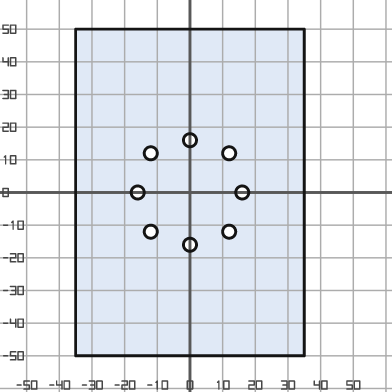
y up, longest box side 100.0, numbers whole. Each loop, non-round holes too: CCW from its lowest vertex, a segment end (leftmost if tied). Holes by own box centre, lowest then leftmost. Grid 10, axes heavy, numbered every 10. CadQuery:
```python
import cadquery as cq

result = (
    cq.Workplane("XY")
    .moveTo(-35.0, -50.0)
    .lineTo(35.0, -50.0)
    .lineTo(35.0, 50.0)
    .lineTo(-35.0, 50.0)
    .close()
    .moveTo(0.0, -16.0)
    .circle(2.0)
    .moveTo(-12.0, -12.0)
    .circle(2.0)
    .moveTo(12.0, -12.0)
    .circle(2.0)
    .moveTo(-16.0, 0.0)
    .circle(2.0)
    .moveTo(16.0, 0.0)
    .circle(2.0)
    .moveTo(-12.0, 12.0)
    .circle(2.0)
    .moveTo(12.0, 12.0)
    .circle(2.0)
    .moveTo(0.0, 16.0)
    .circle(2.0)
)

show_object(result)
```